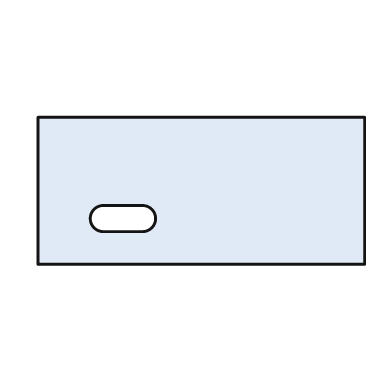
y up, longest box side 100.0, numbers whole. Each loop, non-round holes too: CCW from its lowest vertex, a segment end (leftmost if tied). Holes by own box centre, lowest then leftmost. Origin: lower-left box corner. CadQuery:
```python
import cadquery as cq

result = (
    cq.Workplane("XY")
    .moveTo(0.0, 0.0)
    .lineTo(100.0, 0.0)
    .lineTo(100.0, 45.0)
    .lineTo(0.0, 45.0)
    .close()
    .moveTo(20.0, 10.0)
    .lineTo(32.0, 10.0)
    .threePointArc((36.0, 14.0), (32.0, 18.0))
    .lineTo(20.0, 18.0)
    .threePointArc((16.0, 14.0), (20.0, 10.0))
    .close()
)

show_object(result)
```